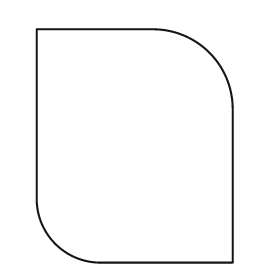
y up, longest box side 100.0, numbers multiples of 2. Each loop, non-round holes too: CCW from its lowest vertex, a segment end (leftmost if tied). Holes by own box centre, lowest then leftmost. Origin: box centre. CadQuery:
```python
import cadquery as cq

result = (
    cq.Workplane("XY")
    .moveTo(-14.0, -50.0)
    .lineTo(42.0, -50.0)
    .lineTo(42.0, 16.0)
    .threePointArc((32.0, 40.0), (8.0, 50.0))
    .lineTo(-42.0, 50.0)
    .lineTo(-42.0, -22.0)
    .threePointArc((-34.0, -42.0), (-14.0, -50.0))
    .close()
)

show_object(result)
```